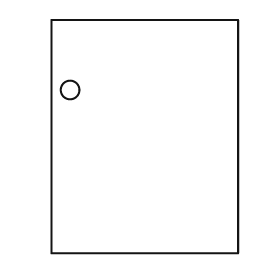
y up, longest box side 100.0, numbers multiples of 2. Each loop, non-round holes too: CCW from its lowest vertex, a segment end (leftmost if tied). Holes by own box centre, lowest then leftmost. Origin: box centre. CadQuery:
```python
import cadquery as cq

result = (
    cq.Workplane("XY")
    .moveTo(-40.0, -50.0)
    .lineTo(40.0, -50.0)
    .lineTo(40.0, 50.0)
    .lineTo(-40.0, 50.0)
    .close()
    .moveTo(-32.0, 20.0)
    .circle(4.0)
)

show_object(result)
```